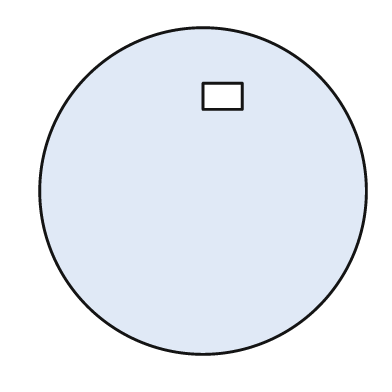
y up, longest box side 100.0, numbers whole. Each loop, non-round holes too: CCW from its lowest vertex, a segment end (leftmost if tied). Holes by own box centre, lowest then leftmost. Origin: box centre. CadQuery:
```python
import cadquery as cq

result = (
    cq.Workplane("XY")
    .moveTo(0.0, 0.0)
    .circle(50.0)
    .moveTo(0.0, 25.0)
    .lineTo(12.0, 25.0)
    .lineTo(12.0, 33.0)
    .lineTo(0.0, 33.0)
    .close()
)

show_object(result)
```